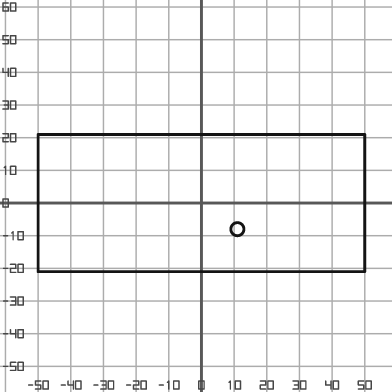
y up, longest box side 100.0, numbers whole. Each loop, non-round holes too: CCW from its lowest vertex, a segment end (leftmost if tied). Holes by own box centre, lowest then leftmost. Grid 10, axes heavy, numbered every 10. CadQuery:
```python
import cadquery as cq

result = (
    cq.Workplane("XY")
    .moveTo(-50.0, -21.0)
    .lineTo(50.0, -21.0)
    .lineTo(50.0, 21.0)
    .lineTo(-50.0, 21.0)
    .close()
    .moveTo(11.0, -8.0)
    .circle(2.0)
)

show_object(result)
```